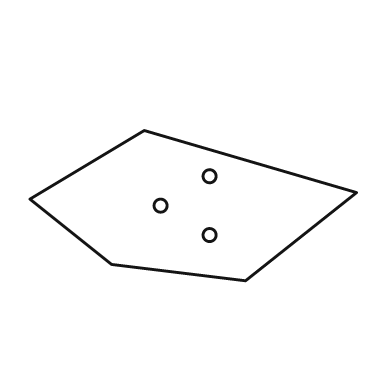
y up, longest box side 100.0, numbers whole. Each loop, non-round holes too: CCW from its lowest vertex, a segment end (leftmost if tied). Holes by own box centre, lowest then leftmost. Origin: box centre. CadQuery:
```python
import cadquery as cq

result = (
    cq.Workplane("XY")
    .moveTo(16.0, -23.0)
    .lineTo(50.0, 4.0)
    .lineTo(-15.0, 23.0)
    .lineTo(-50.0, 2.0)
    .lineTo(-25.0, -18.0)
    .close()
    .moveTo(5.0, -9.0)
    .circle(2.0)
    .moveTo(-10.0, 0.0)
    .circle(2.0)
    .moveTo(5.0, 9.0)
    .circle(2.0)
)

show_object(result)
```